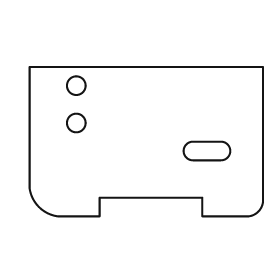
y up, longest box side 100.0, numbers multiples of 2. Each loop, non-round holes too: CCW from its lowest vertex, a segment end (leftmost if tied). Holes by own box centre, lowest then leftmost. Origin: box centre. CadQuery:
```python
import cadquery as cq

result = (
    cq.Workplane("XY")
    .moveTo(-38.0, -32.0)
    .lineTo(-20.0, -32.0)
    .lineTo(-20.0, -24.0)
    .lineTo(24.0, -24.0)
    .lineTo(24.0, -32.0)
    .lineTo(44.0, -32.0)
    .threePointArc((48.0, -30.0), (50.0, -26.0))
    .lineTo(50.0, 32.0)
    .lineTo(-50.0, 32.0)
    .lineTo(-50.0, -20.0)
    .threePointArc((-46.0, -28.0), (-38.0, -32.0))
    .close()
    .moveTo(20.0, -8.0)
    .lineTo(32.0, -8.0)
    .threePointArc((36.0, -4.0), (32.0, 0.0))
    .lineTo(20.0, 0.0)
    .threePointArc((16.0, -4.0), (20.0, -8.0))
    .close()
    .moveTo(-30.0, 8.0)
    .circle(4.0)
    .moveTo(-30.0, 24.0)
    .circle(4.0)
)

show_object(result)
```